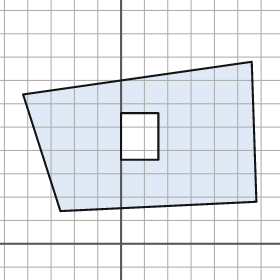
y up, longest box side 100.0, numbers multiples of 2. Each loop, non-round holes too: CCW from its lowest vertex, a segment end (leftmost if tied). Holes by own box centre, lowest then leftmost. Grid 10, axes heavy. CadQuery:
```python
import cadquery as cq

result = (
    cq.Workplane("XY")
    .moveTo(-26.0, 14.0)
    .lineTo(58.0, 18.0)
    .lineTo(56.0, 78.0)
    .lineTo(-42.0, 64.0)
    .close()
    .moveTo(0.0, 36.0)
    .lineTo(16.0, 36.0)
    .lineTo(16.0, 56.0)
    .lineTo(0.0, 56.0)
    .close()
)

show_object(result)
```